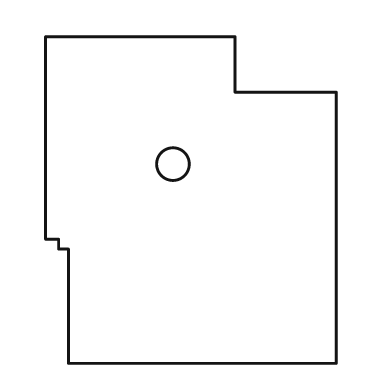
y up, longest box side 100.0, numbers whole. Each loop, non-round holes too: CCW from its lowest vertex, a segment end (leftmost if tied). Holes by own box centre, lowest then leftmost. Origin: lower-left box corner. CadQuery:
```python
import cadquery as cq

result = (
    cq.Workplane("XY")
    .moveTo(7.0, 0.0)
    .lineTo(89.0, 0.0)
    .lineTo(89.0, 83.0)
    .lineTo(58.0, 83.0)
    .lineTo(58.0, 100.0)
    .lineTo(0.0, 100.0)
    .lineTo(0.0, 38.0)
    .lineTo(4.0, 38.0)
    .lineTo(4.0, 35.0)
    .lineTo(7.0, 35.0)
    .close()
    .moveTo(39.0, 61.0)
    .circle(5.0)
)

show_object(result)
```